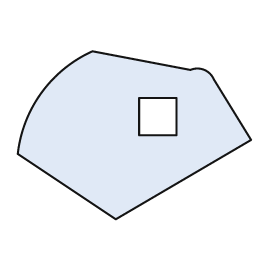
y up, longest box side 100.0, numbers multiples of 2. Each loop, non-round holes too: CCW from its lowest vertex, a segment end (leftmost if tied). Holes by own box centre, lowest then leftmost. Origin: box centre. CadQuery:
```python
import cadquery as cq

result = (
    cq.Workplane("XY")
    .moveTo(-8.0, -36.0)
    .lineTo(50.0, -2.0)
    .lineTo(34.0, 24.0)
    .threePointArc((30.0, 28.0), (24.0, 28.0))
    .lineTo(-18.0, 36.0)
    .threePointArc((-40.0, 18.0), (-50.0, -8.0))
    .close()
    .moveTo(2.0, 0.0)
    .lineTo(18.0, 0.0)
    .lineTo(18.0, 16.0)
    .lineTo(2.0, 16.0)
    .close()
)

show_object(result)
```